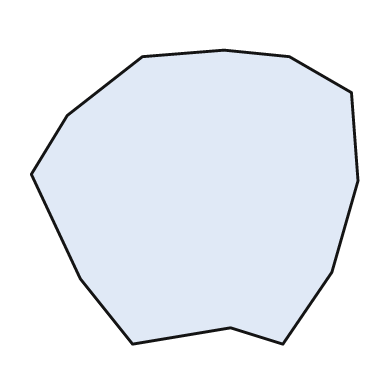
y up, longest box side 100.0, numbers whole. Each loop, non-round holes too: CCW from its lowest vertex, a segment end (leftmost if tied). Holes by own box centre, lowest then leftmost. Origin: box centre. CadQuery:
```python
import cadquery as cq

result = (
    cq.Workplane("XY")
    .moveTo(-19.0, -45.0)
    .lineTo(11.0, -40.0)
    .lineTo(27.0, -45.0)
    .lineTo(42.0, -23.0)
    .lineTo(50.0, 5.0)
    .lineTo(48.0, 32.0)
    .lineTo(29.0, 43.0)
    .lineTo(9.0, 45.0)
    .lineTo(-16.0, 43.0)
    .lineTo(-39.0, 25.0)
    .lineTo(-50.0, 7.0)
    .lineTo(-35.0, -25.0)
    .close()
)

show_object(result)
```